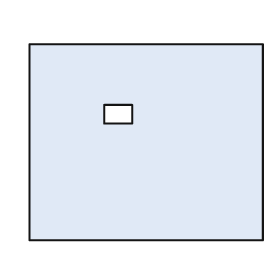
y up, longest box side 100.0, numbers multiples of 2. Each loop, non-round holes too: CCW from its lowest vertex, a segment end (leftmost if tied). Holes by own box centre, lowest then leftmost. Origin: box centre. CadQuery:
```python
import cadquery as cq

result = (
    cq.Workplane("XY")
    .moveTo(-50.0, -42.0)
    .lineTo(50.0, -42.0)
    .lineTo(50.0, 42.0)
    .lineTo(-50.0, 42.0)
    .close()
    .moveTo(-18.0, 8.0)
    .lineTo(-6.0, 8.0)
    .lineTo(-6.0, 16.0)
    .lineTo(-18.0, 16.0)
    .close()
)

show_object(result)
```